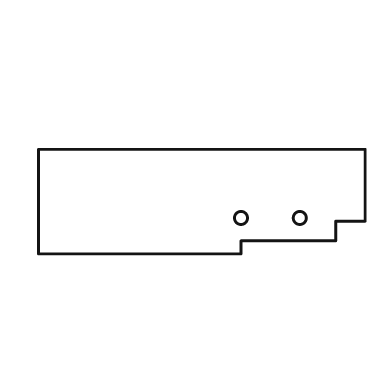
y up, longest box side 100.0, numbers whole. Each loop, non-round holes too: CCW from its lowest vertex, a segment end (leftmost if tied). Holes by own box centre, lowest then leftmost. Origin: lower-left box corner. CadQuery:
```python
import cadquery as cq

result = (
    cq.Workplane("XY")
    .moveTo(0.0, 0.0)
    .lineTo(62.0, 0.0)
    .lineTo(62.0, 4.0)
    .lineTo(91.0, 4.0)
    .lineTo(91.0, 10.0)
    .lineTo(100.0, 10.0)
    .lineTo(100.0, 32.0)
    .lineTo(0.0, 32.0)
    .close()
    .moveTo(62.0, 11.0)
    .circle(2.0)
    .moveTo(80.0, 11.0)
    .circle(2.0)
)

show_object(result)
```